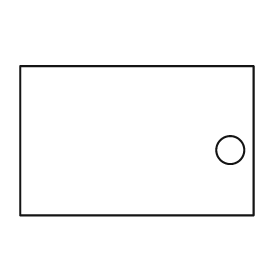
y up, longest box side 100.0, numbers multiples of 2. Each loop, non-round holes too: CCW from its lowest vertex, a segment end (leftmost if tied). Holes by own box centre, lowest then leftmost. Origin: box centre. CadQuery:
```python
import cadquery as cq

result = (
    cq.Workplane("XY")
    .moveTo(-50.0, -32.0)
    .lineTo(50.0, -32.0)
    .lineTo(50.0, 32.0)
    .lineTo(-50.0, 32.0)
    .close()
    .moveTo(40.0, -4.0)
    .circle(6.0)
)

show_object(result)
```